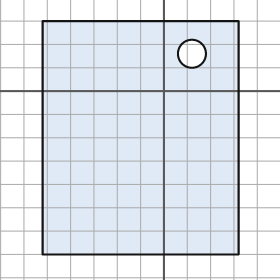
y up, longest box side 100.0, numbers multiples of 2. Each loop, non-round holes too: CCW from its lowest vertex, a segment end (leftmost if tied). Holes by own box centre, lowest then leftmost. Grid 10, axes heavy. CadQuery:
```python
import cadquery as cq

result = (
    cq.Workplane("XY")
    .moveTo(-52.0, -70.0)
    .lineTo(32.0, -70.0)
    .lineTo(32.0, 30.0)
    .lineTo(-52.0, 30.0)
    .close()
    .moveTo(12.0, 16.0)
    .circle(6.0)
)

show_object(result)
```